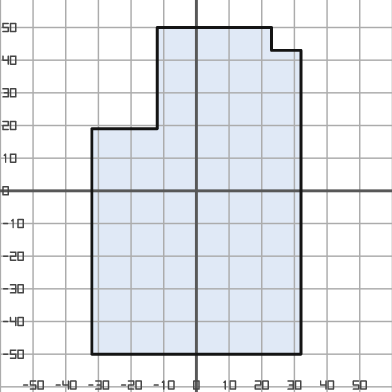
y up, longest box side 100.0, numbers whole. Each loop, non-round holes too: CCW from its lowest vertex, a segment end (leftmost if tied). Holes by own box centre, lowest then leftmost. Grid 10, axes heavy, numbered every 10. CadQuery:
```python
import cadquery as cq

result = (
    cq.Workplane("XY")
    .moveTo(-32.0, -50.0)
    .lineTo(32.0, -50.0)
    .lineTo(32.0, 43.0)
    .lineTo(23.0, 43.0)
    .lineTo(23.0, 50.0)
    .lineTo(-12.0, 50.0)
    .lineTo(-12.0, 19.0)
    .lineTo(-32.0, 19.0)
    .close()
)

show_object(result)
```